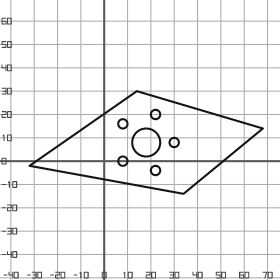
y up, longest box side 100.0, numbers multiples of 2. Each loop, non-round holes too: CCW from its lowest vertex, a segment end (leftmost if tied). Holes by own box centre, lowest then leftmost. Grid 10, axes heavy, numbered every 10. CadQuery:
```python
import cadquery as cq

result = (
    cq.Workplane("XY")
    .moveTo(34.0, -14.0)
    .lineTo(68.0, 14.0)
    .lineTo(14.0, 30.0)
    .lineTo(-32.0, -2.0)
    .close()
    .moveTo(22.0, -4.0)
    .circle(2.0)
    .moveTo(8.0, 0.0)
    .circle(2.0)
    .moveTo(18.0, 8.0)
    .circle(6.0)
    .moveTo(30.0, 8.0)
    .circle(2.0)
    .moveTo(8.0, 16.0)
    .circle(2.0)
    .moveTo(22.0, 20.0)
    .circle(2.0)
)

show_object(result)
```